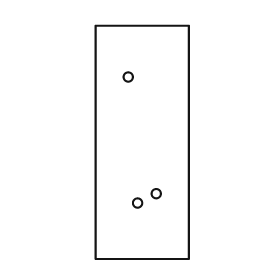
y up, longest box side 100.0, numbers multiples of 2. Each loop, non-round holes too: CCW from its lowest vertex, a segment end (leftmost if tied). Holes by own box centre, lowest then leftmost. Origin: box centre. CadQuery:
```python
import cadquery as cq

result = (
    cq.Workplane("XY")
    .moveTo(-20.0, -50.0)
    .lineTo(20.0, -50.0)
    .lineTo(20.0, 50.0)
    .lineTo(-20.0, 50.0)
    .close()
    .moveTo(-2.0, -26.0)
    .circle(2.0)
    .moveTo(6.0, -22.0)
    .circle(2.0)
    .moveTo(-6.0, 28.0)
    .circle(2.0)
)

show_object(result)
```